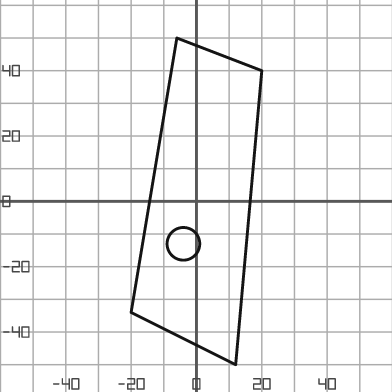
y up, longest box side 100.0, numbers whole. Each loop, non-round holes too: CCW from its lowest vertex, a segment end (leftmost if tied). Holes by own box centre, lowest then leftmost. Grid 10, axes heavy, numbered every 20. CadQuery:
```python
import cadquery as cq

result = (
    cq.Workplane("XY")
    .moveTo(12.0, -50.0)
    .lineTo(20.0, 40.0)
    .lineTo(-6.0, 50.0)
    .lineTo(-20.0, -34.0)
    .close()
    .moveTo(-4.0, -13.0)
    .circle(5.0)
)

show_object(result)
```